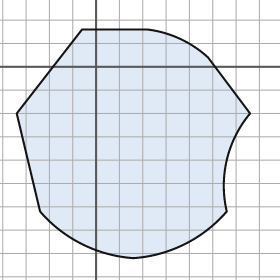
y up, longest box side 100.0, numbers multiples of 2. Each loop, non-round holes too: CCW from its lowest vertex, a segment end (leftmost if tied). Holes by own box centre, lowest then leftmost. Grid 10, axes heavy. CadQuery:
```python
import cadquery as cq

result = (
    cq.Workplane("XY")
    .moveTo(16.0, -82.0)
    .threePointArc((38.0, -76.0), (56.0, -62.0))
    .threePointArc((56.0, -40.0), (66.0, -20.0))
    .lineTo(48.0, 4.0)
    .threePointArc((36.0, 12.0), (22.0, 16.0))
    .lineTo(-6.0, 16.0)
    .lineTo(-34.0, -20.0)
    .lineTo(-24.0, -62.0)
    .threePointArc((-6.0, -76.0), (16.0, -82.0))
    .close()
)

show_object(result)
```